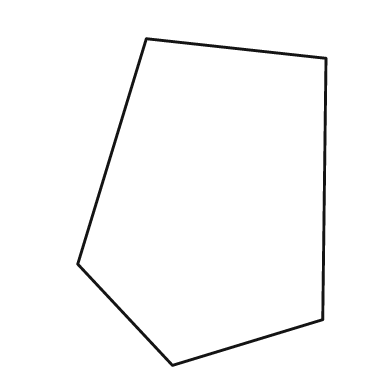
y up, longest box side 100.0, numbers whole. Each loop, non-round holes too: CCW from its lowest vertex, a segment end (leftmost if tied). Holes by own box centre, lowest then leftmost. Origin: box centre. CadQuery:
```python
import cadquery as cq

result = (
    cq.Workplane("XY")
    .moveTo(-9.0, -50.0)
    .lineTo(37.0, -36.0)
    .lineTo(38.0, 44.0)
    .lineTo(-17.0, 50.0)
    .lineTo(-38.0, -19.0)
    .close()
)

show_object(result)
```